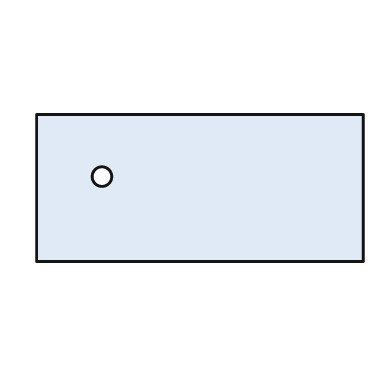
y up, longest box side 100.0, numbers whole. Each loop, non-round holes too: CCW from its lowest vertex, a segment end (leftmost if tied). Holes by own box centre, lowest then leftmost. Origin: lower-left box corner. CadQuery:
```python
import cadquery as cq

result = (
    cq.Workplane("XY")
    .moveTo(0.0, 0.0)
    .lineTo(100.0, 0.0)
    .lineTo(100.0, 45.0)
    .lineTo(0.0, 45.0)
    .close()
    .moveTo(20.0, 26.0)
    .circle(3.0)
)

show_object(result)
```